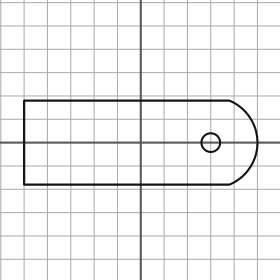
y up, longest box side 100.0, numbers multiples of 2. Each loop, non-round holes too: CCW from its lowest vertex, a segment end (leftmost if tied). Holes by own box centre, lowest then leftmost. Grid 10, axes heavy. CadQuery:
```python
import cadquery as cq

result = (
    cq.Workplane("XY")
    .moveTo(-50.0, -18.0)
    .lineTo(38.0, -18.0)
    .threePointArc((50.0, 0.0), (38.0, 18.0))
    .lineTo(-50.0, 18.0)
    .close()
    .moveTo(30.0, 0.0)
    .circle(4.0)
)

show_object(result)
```